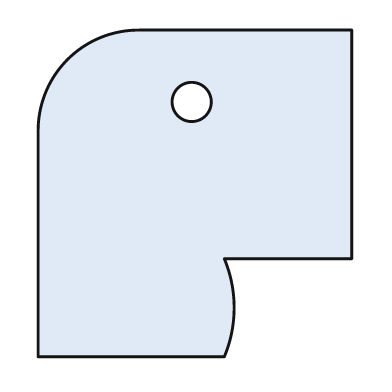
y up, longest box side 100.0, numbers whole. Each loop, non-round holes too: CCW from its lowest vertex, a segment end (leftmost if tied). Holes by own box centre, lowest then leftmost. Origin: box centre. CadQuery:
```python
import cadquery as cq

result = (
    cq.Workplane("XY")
    .moveTo(-48.0, -50.0)
    .lineTo(9.0, -50.0)
    .threePointArc((12.0, -35.0), (9.0, -20.0))
    .lineTo(48.0, -20.0)
    .lineTo(48.0, 50.0)
    .lineTo(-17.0, 50.0)
    .threePointArc((-39.0, 41.0), (-48.0, 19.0))
    .close()
    .moveTo(-1.0, 28.0)
    .circle(6.0)
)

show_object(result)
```